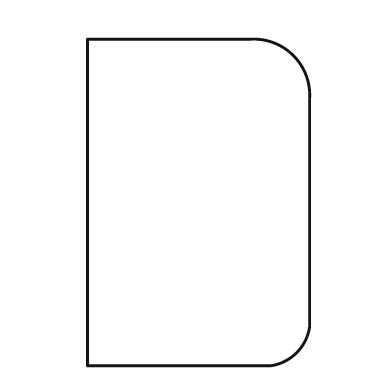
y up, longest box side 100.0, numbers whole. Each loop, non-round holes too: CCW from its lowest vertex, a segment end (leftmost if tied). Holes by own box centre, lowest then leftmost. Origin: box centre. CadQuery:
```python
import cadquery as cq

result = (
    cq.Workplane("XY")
    .moveTo(-34.0, -50.0)
    .lineTo(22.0, -50.0)
    .threePointArc((30.0, -46.0), (34.0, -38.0))
    .lineTo(34.0, 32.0)
    .threePointArc((29.0, 45.0), (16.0, 50.0))
    .lineTo(-34.0, 50.0)
    .close()
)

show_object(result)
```